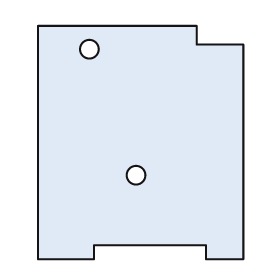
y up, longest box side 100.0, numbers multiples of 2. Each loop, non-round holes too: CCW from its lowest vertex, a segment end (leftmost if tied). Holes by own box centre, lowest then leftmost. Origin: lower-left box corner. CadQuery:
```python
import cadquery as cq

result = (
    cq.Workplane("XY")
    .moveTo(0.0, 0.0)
    .lineTo(24.0, 0.0)
    .lineTo(24.0, 6.0)
    .lineTo(72.0, 6.0)
    .lineTo(72.0, 0.0)
    .lineTo(88.0, 0.0)
    .lineTo(88.0, 92.0)
    .lineTo(68.0, 92.0)
    .lineTo(68.0, 100.0)
    .lineTo(0.0, 100.0)
    .close()
    .moveTo(42.0, 36.0)
    .circle(4.0)
    .moveTo(22.0, 90.0)
    .circle(4.0)
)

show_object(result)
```